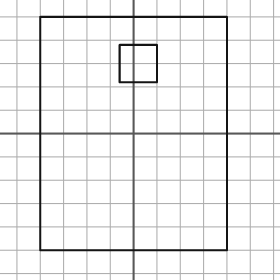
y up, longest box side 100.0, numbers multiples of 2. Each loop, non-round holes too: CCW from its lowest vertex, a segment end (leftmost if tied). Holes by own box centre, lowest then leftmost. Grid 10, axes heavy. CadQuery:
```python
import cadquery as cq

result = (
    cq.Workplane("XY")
    .moveTo(-40.0, -50.0)
    .lineTo(40.0, -50.0)
    .lineTo(40.0, 50.0)
    .lineTo(-40.0, 50.0)
    .close()
    .moveTo(-6.0, 22.0)
    .lineTo(10.0, 22.0)
    .lineTo(10.0, 38.0)
    .lineTo(-6.0, 38.0)
    .close()
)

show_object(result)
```